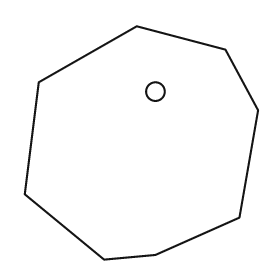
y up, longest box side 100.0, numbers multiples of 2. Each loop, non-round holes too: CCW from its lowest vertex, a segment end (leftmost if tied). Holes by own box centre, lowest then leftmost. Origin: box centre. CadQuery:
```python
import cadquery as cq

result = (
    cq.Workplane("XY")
    .moveTo(-16.0, -50.0)
    .lineTo(6.0, -48.0)
    .lineTo(42.0, -32.0)
    .lineTo(50.0, 14.0)
    .lineTo(36.0, 40.0)
    .lineTo(-2.0, 50.0)
    .lineTo(-44.0, 26.0)
    .lineTo(-50.0, -22.0)
    .close()
    .moveTo(6.0, 22.0)
    .circle(4.0)
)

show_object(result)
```